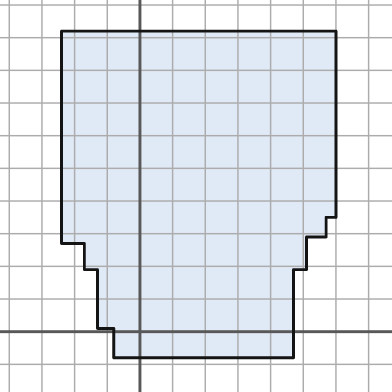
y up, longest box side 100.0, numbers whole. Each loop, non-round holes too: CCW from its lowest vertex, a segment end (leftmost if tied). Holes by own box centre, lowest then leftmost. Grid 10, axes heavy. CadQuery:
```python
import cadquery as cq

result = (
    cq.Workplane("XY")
    .moveTo(-8.0, -8.0)
    .lineTo(47.0, -8.0)
    .lineTo(47.0, 19.0)
    .lineTo(51.0, 19.0)
    .lineTo(51.0, 29.0)
    .lineTo(57.0, 29.0)
    .lineTo(57.0, 35.0)
    .lineTo(60.0, 35.0)
    .lineTo(60.0, 92.0)
    .lineTo(-24.0, 92.0)
    .lineTo(-24.0, 27.0)
    .lineTo(-17.0, 27.0)
    .lineTo(-17.0, 19.0)
    .lineTo(-13.0, 19.0)
    .lineTo(-13.0, 1.0)
    .lineTo(-8.0, 1.0)
    .close()
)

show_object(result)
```